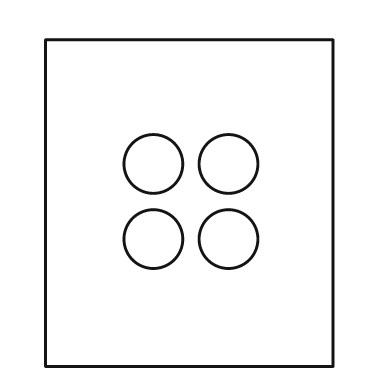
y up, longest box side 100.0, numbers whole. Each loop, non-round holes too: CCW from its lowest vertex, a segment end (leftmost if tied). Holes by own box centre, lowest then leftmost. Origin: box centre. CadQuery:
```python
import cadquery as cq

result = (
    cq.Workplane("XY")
    .moveTo(-44.0, -50.0)
    .lineTo(44.0, -50.0)
    .lineTo(44.0, 50.0)
    .lineTo(-44.0, 50.0)
    .close()
    .moveTo(-11.0, -11.0)
    .circle(9.0)
    .moveTo(12.0, -11.0)
    .circle(9.0)
    .moveTo(-11.0, 12.0)
    .circle(9.0)
    .moveTo(12.0, 12.0)
    .circle(9.0)
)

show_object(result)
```